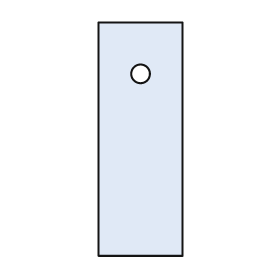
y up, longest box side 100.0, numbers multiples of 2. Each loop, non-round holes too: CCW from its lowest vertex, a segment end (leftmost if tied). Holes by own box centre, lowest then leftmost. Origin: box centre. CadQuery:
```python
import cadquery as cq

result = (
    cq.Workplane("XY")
    .moveTo(-18.0, -50.0)
    .lineTo(18.0, -50.0)
    .lineTo(18.0, 50.0)
    .lineTo(-18.0, 50.0)
    .close()
    .moveTo(0.0, 28.0)
    .circle(4.0)
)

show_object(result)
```